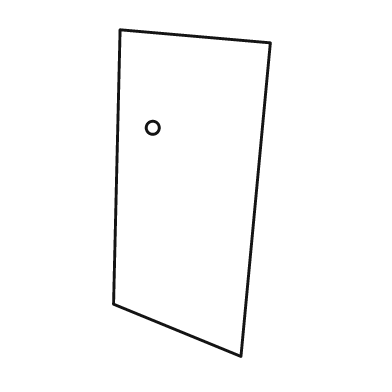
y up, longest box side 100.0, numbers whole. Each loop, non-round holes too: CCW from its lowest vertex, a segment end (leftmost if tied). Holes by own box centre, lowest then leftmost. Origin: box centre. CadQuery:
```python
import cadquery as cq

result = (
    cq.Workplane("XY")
    .moveTo(15.0, -50.0)
    .lineTo(24.0, 46.0)
    .lineTo(-22.0, 50.0)
    .lineTo(-24.0, -34.0)
    .close()
    .moveTo(-12.0, 20.0)
    .circle(2.0)
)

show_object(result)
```